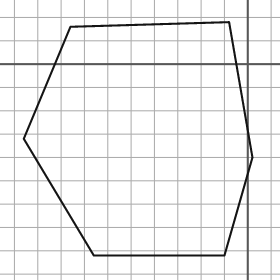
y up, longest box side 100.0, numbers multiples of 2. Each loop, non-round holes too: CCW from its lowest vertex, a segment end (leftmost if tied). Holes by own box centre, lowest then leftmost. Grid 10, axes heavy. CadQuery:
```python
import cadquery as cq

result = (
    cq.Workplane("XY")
    .moveTo(-66.0, -82.0)
    .lineTo(-10.0, -82.0)
    .lineTo(2.0, -40.0)
    .lineTo(-8.0, 18.0)
    .lineTo(-76.0, 16.0)
    .lineTo(-96.0, -32.0)
    .close()
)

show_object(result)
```